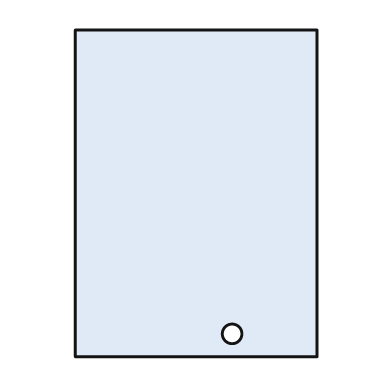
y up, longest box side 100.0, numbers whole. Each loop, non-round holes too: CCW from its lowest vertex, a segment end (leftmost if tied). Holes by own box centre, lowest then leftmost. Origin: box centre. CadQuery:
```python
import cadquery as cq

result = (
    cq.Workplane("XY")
    .moveTo(-37.0, -50.0)
    .lineTo(37.0, -50.0)
    .lineTo(37.0, 50.0)
    .lineTo(-37.0, 50.0)
    .close()
    .moveTo(11.0, -43.0)
    .circle(3.0)
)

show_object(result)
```